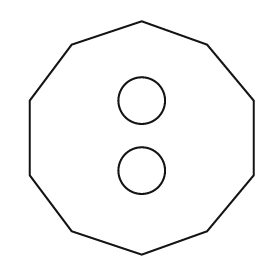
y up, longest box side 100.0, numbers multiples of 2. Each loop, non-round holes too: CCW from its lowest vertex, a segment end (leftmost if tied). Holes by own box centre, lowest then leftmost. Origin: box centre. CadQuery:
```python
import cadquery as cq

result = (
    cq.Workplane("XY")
    .moveTo(0.0, -50.0)
    .lineTo(28.0, -40.0)
    .lineTo(48.0, -16.0)
    .lineTo(48.0, 16.0)
    .lineTo(28.0, 40.0)
    .lineTo(0.0, 50.0)
    .lineTo(-30.0, 40.0)
    .lineTo(-48.0, 16.0)
    .lineTo(-48.0, -16.0)
    .lineTo(-30.0, -40.0)
    .close()
    .moveTo(0.0, -14.0)
    .circle(10.0)
    .moveTo(0.0, 16.0)
    .circle(10.0)
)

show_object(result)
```